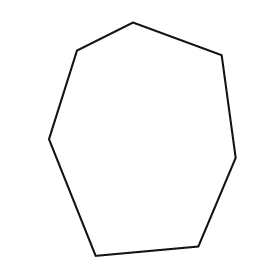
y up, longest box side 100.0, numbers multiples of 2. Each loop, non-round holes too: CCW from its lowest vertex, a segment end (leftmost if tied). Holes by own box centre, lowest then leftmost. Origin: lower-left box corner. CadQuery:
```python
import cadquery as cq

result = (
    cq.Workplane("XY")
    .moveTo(20.0, 0.0)
    .lineTo(64.0, 4.0)
    .lineTo(80.0, 42.0)
    .lineTo(74.0, 86.0)
    .lineTo(36.0, 100.0)
    .lineTo(12.0, 88.0)
    .lineTo(0.0, 50.0)
    .close()
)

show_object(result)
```